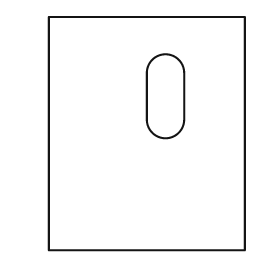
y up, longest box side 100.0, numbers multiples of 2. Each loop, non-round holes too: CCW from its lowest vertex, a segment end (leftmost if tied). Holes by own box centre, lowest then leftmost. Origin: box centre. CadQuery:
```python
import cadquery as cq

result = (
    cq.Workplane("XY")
    .moveTo(-42.0, -50.0)
    .lineTo(42.0, -50.0)
    .lineTo(42.0, 50.0)
    .lineTo(-42.0, 50.0)
    .close()
    .moveTo(0.0, 6.0)
    .threePointArc((8.0, -2.0), (16.0, 6.0))
    .lineTo(16.0, 26.0)
    .threePointArc((8.0, 34.0), (0.0, 26.0))
    .close()
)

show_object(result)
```